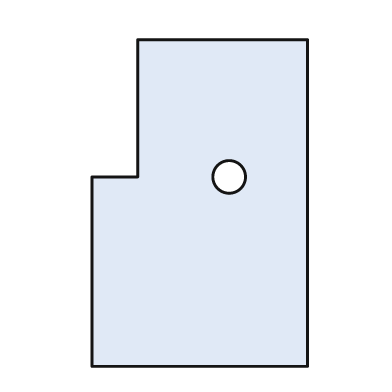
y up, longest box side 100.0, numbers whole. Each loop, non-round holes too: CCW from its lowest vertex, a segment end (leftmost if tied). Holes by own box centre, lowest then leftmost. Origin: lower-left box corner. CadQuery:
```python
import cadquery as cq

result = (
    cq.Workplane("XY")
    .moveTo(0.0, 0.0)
    .lineTo(66.0, 0.0)
    .lineTo(66.0, 100.0)
    .lineTo(14.0, 100.0)
    .lineTo(14.0, 58.0)
    .lineTo(0.0, 58.0)
    .close()
    .moveTo(42.0, 58.0)
    .circle(5.0)
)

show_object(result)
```